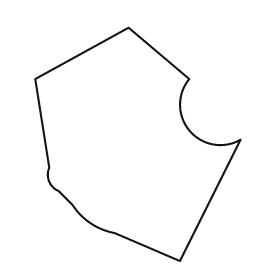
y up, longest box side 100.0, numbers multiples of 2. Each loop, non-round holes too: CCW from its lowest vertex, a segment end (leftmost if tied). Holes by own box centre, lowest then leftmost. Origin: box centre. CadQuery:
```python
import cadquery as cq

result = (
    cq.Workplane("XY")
    .moveTo(18.0, -50.0)
    .lineTo(44.0, 2.0)
    .threePointArc((22.0, 6.0), (22.0, 28.0))
    .lineTo(-4.0, 50.0)
    .lineTo(-44.0, 28.0)
    .lineTo(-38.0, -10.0)
    .threePointArc((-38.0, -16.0), (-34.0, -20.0))
    .lineTo(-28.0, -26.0)
    .threePointArc((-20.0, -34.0), (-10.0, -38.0))
    .close()
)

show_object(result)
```